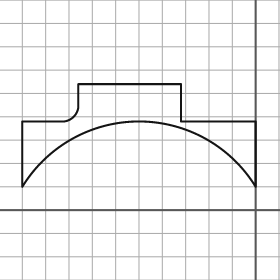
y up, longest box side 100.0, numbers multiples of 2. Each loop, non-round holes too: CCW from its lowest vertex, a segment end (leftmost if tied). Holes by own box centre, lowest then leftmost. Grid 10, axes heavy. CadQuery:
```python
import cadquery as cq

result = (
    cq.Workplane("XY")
    .moveTo(-100.0, 10.0)
    .threePointArc((-50.0, 38.0), (0.0, 10.0))
    .lineTo(0.0, 38.0)
    .lineTo(-32.0, 38.0)
    .lineTo(-32.0, 54.0)
    .lineTo(-76.0, 54.0)
    .lineTo(-76.0, 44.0)
    .threePointArc((-78.0, 40.0), (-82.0, 38.0))
    .lineTo(-100.0, 38.0)
    .close()
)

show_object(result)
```